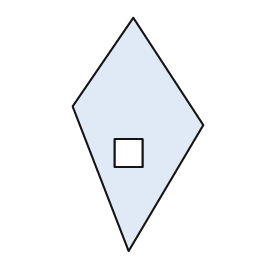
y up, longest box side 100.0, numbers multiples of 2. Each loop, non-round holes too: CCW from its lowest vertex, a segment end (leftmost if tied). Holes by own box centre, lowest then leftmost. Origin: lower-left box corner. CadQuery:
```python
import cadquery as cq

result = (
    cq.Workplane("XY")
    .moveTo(24.0, 0.0)
    .lineTo(56.0, 54.0)
    .lineTo(26.0, 100.0)
    .lineTo(0.0, 62.0)
    .close()
    .moveTo(18.0, 36.0)
    .lineTo(30.0, 36.0)
    .lineTo(30.0, 48.0)
    .lineTo(18.0, 48.0)
    .close()
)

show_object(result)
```